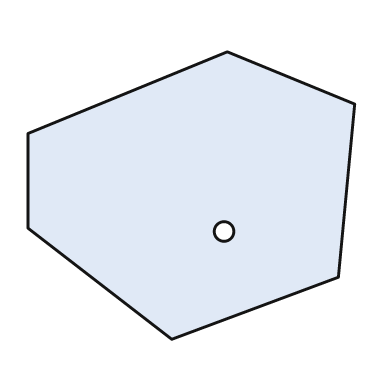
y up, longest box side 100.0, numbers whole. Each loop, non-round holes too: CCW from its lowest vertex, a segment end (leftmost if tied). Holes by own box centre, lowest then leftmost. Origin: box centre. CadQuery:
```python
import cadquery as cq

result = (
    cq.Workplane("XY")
    .moveTo(-6.0, -44.0)
    .lineTo(45.0, -25.0)
    .lineTo(50.0, 28.0)
    .lineTo(11.0, 44.0)
    .lineTo(-50.0, 19.0)
    .lineTo(-50.0, -10.0)
    .close()
    .moveTo(10.0, -11.0)
    .circle(3.0)
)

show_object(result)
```